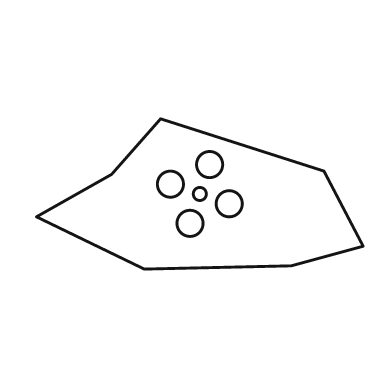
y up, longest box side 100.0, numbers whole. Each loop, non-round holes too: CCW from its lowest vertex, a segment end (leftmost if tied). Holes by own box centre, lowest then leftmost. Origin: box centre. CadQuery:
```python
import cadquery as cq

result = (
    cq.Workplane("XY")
    .moveTo(-17.0, -23.0)
    .lineTo(28.0, -22.0)
    .lineTo(50.0, -16.0)
    .lineTo(38.0, 7.0)
    .lineTo(-12.0, 23.0)
    .lineTo(-27.0, 6.0)
    .lineTo(-50.0, -7.0)
    .close()
    .moveTo(-3.0, -9.0)
    .circle(4.0)
    .moveTo(9.0, -3.0)
    .circle(4.0)
    .moveTo(0.0, 0.0)
    .circle(2.0)
    .moveTo(-9.0, 3.0)
    .circle(4.0)
    .moveTo(3.0, 9.0)
    .circle(4.0)
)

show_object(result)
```